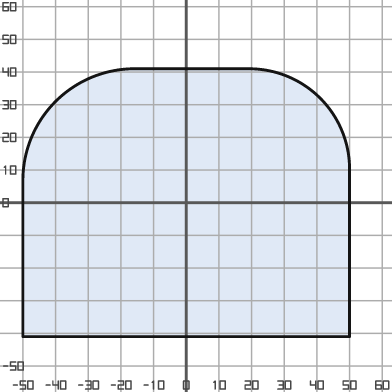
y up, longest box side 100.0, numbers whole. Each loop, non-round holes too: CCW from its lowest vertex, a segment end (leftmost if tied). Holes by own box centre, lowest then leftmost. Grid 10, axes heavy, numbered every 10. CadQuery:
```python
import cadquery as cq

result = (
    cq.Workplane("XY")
    .moveTo(-50.0, -41.0)
    .lineTo(50.0, -41.0)
    .lineTo(50.0, 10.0)
    .threePointArc((41.0, 32.0), (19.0, 41.0))
    .lineTo(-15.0, 41.0)
    .threePointArc((-40.0, 31.0), (-50.0, 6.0))
    .close()
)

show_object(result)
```